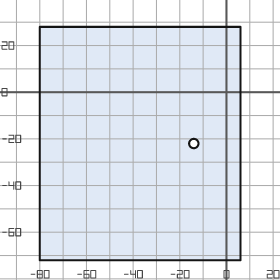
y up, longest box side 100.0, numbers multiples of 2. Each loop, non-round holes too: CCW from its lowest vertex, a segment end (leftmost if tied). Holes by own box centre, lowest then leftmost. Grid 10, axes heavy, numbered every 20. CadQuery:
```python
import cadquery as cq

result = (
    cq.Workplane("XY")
    .moveTo(-80.0, -72.0)
    .lineTo(6.0, -72.0)
    .lineTo(6.0, 28.0)
    .lineTo(-80.0, 28.0)
    .close()
    .moveTo(-14.0, -22.0)
    .circle(2.0)
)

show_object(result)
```